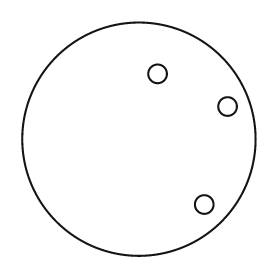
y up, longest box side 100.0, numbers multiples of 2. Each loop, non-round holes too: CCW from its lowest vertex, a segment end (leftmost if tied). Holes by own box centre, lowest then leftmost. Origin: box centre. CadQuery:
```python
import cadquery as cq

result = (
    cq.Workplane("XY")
    .moveTo(0.0, 0.0)
    .circle(50.0)
    .moveTo(28.0, -28.0)
    .circle(4.0)
    .moveTo(38.0, 14.0)
    .circle(4.0)
    .moveTo(8.0, 28.0)
    .circle(4.0)
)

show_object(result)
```